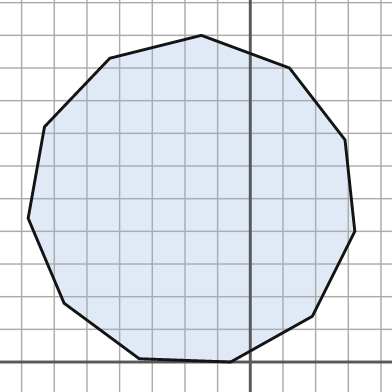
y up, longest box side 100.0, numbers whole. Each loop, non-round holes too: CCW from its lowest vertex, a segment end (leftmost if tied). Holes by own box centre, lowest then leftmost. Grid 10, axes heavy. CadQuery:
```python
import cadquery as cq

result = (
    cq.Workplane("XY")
    .moveTo(-6.0, 0.0)
    .lineTo(19.0, 14.0)
    .lineTo(32.0, 40.0)
    .lineTo(29.0, 68.0)
    .lineTo(12.0, 90.0)
    .lineTo(-15.0, 100.0)
    .lineTo(-43.0, 93.0)
    .lineTo(-63.0, 72.0)
    .lineTo(-68.0, 44.0)
    .lineTo(-57.0, 18.0)
    .lineTo(-34.0, 1.0)
    .close()
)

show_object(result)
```